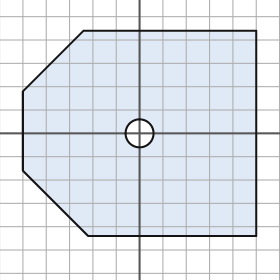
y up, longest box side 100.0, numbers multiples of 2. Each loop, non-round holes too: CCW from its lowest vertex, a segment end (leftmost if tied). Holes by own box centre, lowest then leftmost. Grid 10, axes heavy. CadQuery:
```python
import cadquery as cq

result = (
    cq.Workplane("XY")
    .moveTo(-22.0, -44.0)
    .lineTo(50.0, -44.0)
    .lineTo(50.0, 44.0)
    .lineTo(-24.0, 44.0)
    .lineTo(-50.0, 18.0)
    .lineTo(-50.0, -16.0)
    .close()
    .moveTo(0.0, 0.0)
    .circle(6.0)
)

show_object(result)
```